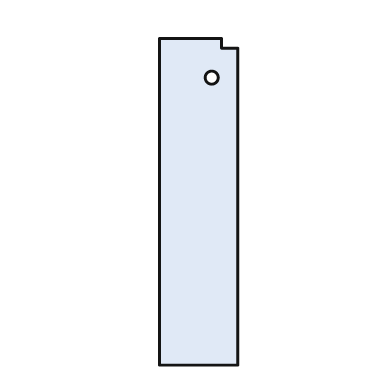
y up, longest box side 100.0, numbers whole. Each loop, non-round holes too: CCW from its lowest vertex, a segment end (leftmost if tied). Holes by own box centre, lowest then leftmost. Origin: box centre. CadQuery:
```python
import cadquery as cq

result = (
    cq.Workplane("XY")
    .moveTo(-12.0, -50.0)
    .lineTo(12.0, -50.0)
    .lineTo(12.0, 47.0)
    .lineTo(7.0, 47.0)
    .lineTo(7.0, 50.0)
    .lineTo(-12.0, 50.0)
    .close()
    .moveTo(4.0, 38.0)
    .circle(2.0)
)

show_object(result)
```